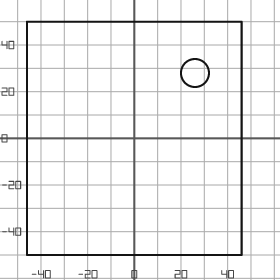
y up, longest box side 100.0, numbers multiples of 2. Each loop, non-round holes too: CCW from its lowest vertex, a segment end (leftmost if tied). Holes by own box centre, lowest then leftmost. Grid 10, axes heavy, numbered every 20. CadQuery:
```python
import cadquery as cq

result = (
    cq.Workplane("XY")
    .moveTo(-46.0, -50.0)
    .lineTo(46.0, -50.0)
    .lineTo(46.0, 50.0)
    .lineTo(-46.0, 50.0)
    .close()
    .moveTo(26.0, 28.0)
    .circle(6.0)
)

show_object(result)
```